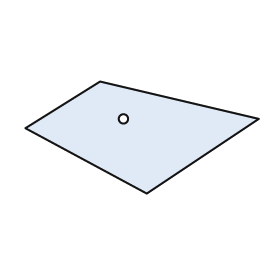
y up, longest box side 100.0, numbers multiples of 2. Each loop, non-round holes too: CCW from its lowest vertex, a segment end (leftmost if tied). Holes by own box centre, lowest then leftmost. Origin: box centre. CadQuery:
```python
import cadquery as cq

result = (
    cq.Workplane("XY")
    .moveTo(2.0, -24.0)
    .lineTo(50.0, 8.0)
    .lineTo(-18.0, 24.0)
    .lineTo(-50.0, 4.0)
    .close()
    .moveTo(-8.0, 8.0)
    .circle(2.0)
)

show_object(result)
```